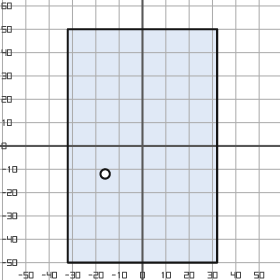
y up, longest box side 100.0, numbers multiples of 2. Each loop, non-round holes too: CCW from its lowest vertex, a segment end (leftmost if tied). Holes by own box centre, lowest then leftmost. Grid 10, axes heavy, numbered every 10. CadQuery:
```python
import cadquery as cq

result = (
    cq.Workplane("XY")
    .moveTo(-32.0, -50.0)
    .lineTo(32.0, -50.0)
    .lineTo(32.0, 50.0)
    .lineTo(-32.0, 50.0)
    .close()
    .moveTo(-16.0, -12.0)
    .circle(2.0)
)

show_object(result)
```